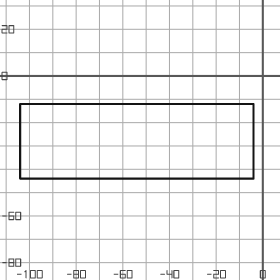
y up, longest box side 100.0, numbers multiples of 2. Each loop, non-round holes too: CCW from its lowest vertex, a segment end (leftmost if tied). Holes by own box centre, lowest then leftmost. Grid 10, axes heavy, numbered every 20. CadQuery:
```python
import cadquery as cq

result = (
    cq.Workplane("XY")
    .moveTo(-104.0, -44.0)
    .lineTo(-4.0, -44.0)
    .lineTo(-4.0, -12.0)
    .lineTo(-104.0, -12.0)
    .close()
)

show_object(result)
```